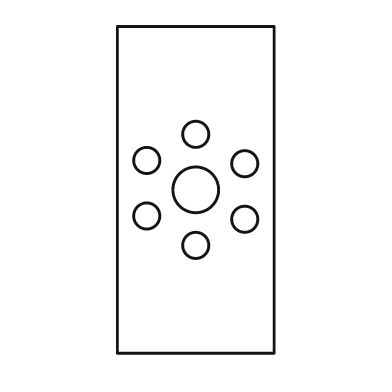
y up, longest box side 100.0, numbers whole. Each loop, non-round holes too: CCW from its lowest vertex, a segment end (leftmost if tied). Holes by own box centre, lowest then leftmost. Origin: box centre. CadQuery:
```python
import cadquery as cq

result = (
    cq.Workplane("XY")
    .moveTo(-24.0, -50.0)
    .lineTo(24.0, -50.0)
    .lineTo(24.0, 50.0)
    .lineTo(-24.0, 50.0)
    .close()
    .moveTo(0.0, -17.0)
    .circle(4.0)
    .moveTo(15.0, -9.0)
    .circle(4.0)
    .moveTo(-15.0, -8.0)
    .circle(4.0)
    .moveTo(0.0, 0.0)
    .circle(7.0)
    .moveTo(15.0, 8.0)
    .circle(4.0)
    .moveTo(-15.0, 9.0)
    .circle(4.0)
    .moveTo(0.0, 17.0)
    .circle(4.0)
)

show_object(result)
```